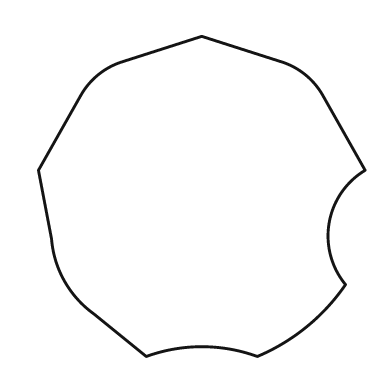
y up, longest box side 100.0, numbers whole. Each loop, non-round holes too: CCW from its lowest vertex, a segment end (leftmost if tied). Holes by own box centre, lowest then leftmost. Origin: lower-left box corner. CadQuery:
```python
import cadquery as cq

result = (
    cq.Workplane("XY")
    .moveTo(33.0, 0.0)
    .threePointArc((50.0, 3.0), (67.0, 0.0))
    .threePointArc((82.0, 9.0), (94.0, 22.0))
    .threePointArc((89.0, 41.0), (100.0, 57.0))
    .lineTo(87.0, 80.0)
    .threePointArc((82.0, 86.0), (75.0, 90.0))
    .lineTo(50.0, 98.0)
    .lineTo(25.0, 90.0)
    .threePointArc((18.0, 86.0), (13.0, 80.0))
    .lineTo(0.0, 57.0)
    .lineTo(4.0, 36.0)
    .threePointArc((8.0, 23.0), (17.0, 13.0))
    .close()
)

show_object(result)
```